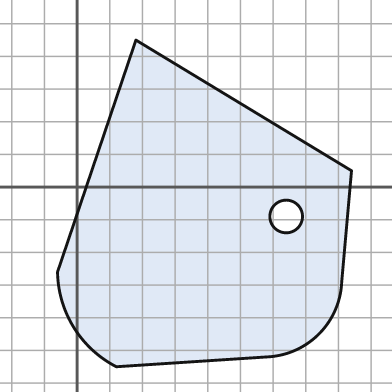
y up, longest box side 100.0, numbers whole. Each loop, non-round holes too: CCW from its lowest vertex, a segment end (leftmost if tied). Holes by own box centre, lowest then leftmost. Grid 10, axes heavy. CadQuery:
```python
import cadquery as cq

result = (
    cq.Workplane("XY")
    .moveTo(12.0, -55.0)
    .lineTo(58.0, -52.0)
    .threePointArc((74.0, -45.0), (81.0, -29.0))
    .lineTo(84.0, 5.0)
    .lineTo(18.0, 45.0)
    .lineTo(-6.0, -26.0)
    .threePointArc((-1.0, -43.0), (12.0, -55.0))
    .close()
    .moveTo(64.0, -9.0)
    .circle(5.0)
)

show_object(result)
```